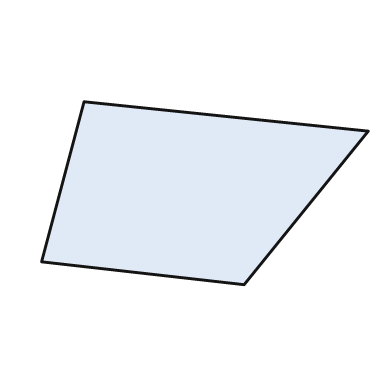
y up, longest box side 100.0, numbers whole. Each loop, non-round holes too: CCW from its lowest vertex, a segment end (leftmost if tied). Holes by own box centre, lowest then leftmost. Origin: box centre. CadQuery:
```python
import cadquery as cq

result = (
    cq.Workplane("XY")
    .moveTo(12.0, -28.0)
    .lineTo(50.0, 19.0)
    .lineTo(-37.0, 28.0)
    .lineTo(-50.0, -21.0)
    .close()
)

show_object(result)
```